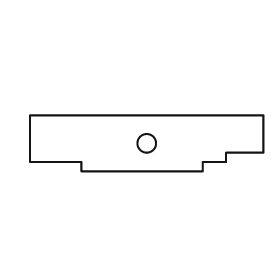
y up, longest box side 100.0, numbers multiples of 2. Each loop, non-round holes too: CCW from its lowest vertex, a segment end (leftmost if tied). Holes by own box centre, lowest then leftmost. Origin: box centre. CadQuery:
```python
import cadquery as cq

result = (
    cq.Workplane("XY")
    .moveTo(-28.0, -12.0)
    .lineTo(24.0, -12.0)
    .lineTo(24.0, -8.0)
    .lineTo(34.0, -8.0)
    .lineTo(34.0, -4.0)
    .lineTo(50.0, -4.0)
    .lineTo(50.0, 12.0)
    .lineTo(-50.0, 12.0)
    .lineTo(-50.0, -8.0)
    .lineTo(-28.0, -8.0)
    .close()
    .moveTo(0.0, 0.0)
    .circle(4.0)
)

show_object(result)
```